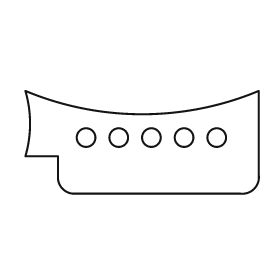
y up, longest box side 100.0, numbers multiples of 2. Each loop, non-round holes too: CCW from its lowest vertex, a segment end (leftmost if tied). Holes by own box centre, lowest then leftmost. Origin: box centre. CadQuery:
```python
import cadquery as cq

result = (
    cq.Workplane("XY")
    .moveTo(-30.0, -22.0)
    .lineTo(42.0, -22.0)
    .threePointArc((48.0, -20.0), (50.0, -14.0))
    .lineTo(50.0, 22.0)
    .threePointArc((0.0, 12.0), (-50.0, 22.0))
    .threePointArc((-48.0, 8.0), (-50.0, -6.0))
    .lineTo(-36.0, -6.0)
    .lineTo(-36.0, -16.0)
    .threePointArc((-34.0, -20.0), (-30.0, -22.0))
    .close()
    .moveTo(-24.0, 2.0)
    .circle(4.0)
    .moveTo(-10.0, 2.0)
    .circle(4.0)
    .moveTo(4.0, 2.0)
    .circle(4.0)
    .moveTo(18.0, 2.0)
    .circle(4.0)
    .moveTo(32.0, 2.0)
    .circle(4.0)
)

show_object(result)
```